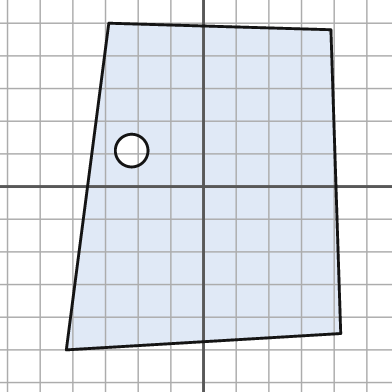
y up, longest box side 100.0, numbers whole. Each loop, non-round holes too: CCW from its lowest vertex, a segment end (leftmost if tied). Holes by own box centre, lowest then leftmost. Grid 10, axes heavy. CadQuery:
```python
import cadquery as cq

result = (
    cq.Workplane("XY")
    .moveTo(-42.0, -50.0)
    .lineTo(42.0, -45.0)
    .lineTo(39.0, 48.0)
    .lineTo(-29.0, 50.0)
    .close()
    .moveTo(-22.0, 11.0)
    .circle(5.0)
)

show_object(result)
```